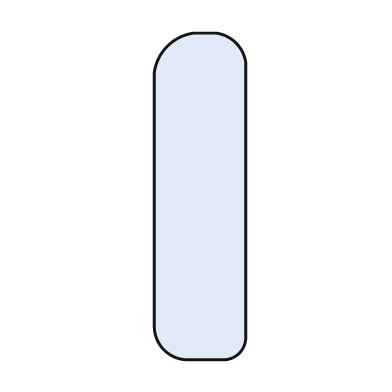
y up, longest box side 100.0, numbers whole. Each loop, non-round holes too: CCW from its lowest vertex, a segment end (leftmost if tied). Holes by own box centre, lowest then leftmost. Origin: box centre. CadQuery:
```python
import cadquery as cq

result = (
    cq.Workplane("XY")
    .moveTo(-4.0, -50.0)
    .lineTo(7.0, -50.0)
    .threePointArc((12.0, -48.0), (14.0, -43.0))
    .lineTo(14.0, 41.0)
    .threePointArc((11.0, 47.0), (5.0, 50.0))
    .lineTo(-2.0, 50.0)
    .threePointArc((-10.0, 46.0), (-14.0, 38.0))
    .lineTo(-14.0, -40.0)
    .threePointArc((-11.0, -47.0), (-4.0, -50.0))
    .close()
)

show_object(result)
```